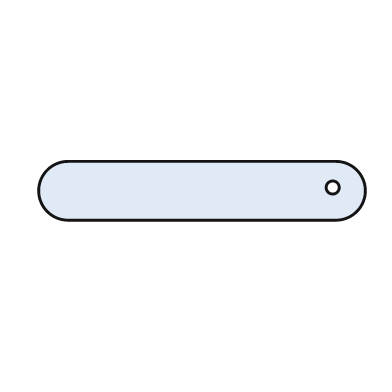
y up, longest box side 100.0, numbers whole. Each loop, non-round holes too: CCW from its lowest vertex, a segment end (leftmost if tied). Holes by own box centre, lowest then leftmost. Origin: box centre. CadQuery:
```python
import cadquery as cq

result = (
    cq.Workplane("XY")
    .moveTo(-41.0, -9.0)
    .lineTo(41.0, -9.0)
    .threePointArc((50.0, 0.0), (41.0, 9.0))
    .lineTo(-41.0, 9.0)
    .threePointArc((-50.0, 0.0), (-41.0, -9.0))
    .close()
    .moveTo(40.0, 1.0)
    .circle(2.0)
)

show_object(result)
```